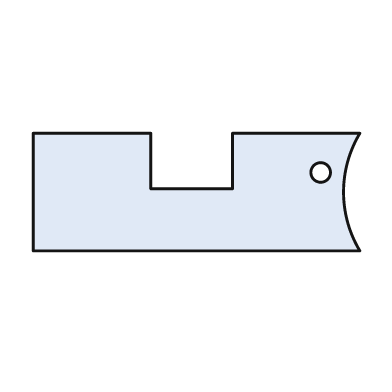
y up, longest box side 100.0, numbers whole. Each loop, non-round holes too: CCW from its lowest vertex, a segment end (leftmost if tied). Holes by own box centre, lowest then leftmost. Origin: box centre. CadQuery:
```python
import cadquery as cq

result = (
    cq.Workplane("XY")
    .moveTo(-50.0, -18.0)
    .lineTo(50.0, -18.0)
    .threePointArc((45.0, 0.0), (50.0, 18.0))
    .lineTo(11.0, 18.0)
    .lineTo(11.0, 1.0)
    .lineTo(-14.0, 1.0)
    .lineTo(-14.0, 18.0)
    .lineTo(-50.0, 18.0)
    .close()
    .moveTo(38.0, 6.0)
    .circle(3.0)
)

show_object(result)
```